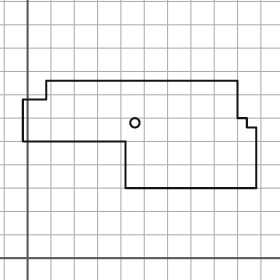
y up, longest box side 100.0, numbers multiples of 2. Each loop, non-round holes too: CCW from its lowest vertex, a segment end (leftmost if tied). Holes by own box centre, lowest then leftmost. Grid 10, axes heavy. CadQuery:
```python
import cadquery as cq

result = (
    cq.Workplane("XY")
    .moveTo(42.0, 30.0)
    .lineTo(98.0, 30.0)
    .lineTo(98.0, 56.0)
    .lineTo(94.0, 56.0)
    .lineTo(94.0, 60.0)
    .lineTo(90.0, 60.0)
    .lineTo(90.0, 76.0)
    .lineTo(8.0, 76.0)
    .lineTo(8.0, 68.0)
    .lineTo(-2.0, 68.0)
    .lineTo(-2.0, 50.0)
    .lineTo(42.0, 50.0)
    .close()
    .moveTo(46.0, 58.0)
    .circle(2.0)
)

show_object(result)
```